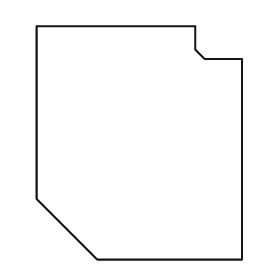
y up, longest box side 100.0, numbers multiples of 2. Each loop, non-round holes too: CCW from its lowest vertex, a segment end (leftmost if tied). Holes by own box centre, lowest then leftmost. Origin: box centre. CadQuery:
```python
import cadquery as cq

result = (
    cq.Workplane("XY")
    .moveTo(-18.0, -50.0)
    .lineTo(44.0, -50.0)
    .lineTo(44.0, 36.0)
    .lineTo(28.0, 36.0)
    .lineTo(24.0, 40.0)
    .lineTo(24.0, 50.0)
    .lineTo(-44.0, 50.0)
    .lineTo(-44.0, -24.0)
    .close()
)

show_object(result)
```